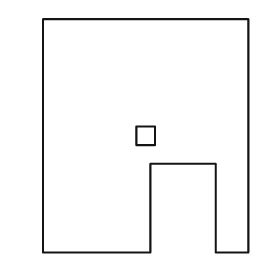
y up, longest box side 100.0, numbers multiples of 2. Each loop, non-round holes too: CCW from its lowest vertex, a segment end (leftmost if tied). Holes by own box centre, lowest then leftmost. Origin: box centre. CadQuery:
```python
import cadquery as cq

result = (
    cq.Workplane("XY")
    .moveTo(-44.0, -50.0)
    .lineTo(2.0, -50.0)
    .lineTo(2.0, -12.0)
    .lineTo(30.0, -12.0)
    .lineTo(30.0, -50.0)
    .lineTo(44.0, -50.0)
    .lineTo(44.0, 50.0)
    .lineTo(-44.0, 50.0)
    .close()
    .moveTo(-4.0, -4.0)
    .lineTo(4.0, -4.0)
    .lineTo(4.0, 4.0)
    .lineTo(-4.0, 4.0)
    .close()
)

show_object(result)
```